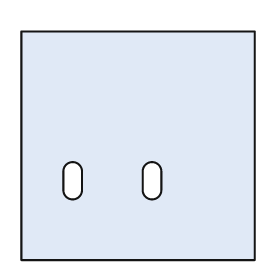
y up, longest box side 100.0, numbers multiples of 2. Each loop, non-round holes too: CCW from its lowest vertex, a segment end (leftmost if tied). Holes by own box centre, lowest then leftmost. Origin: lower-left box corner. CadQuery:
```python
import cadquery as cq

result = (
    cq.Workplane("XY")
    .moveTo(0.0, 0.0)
    .lineTo(100.0, 0.0)
    .lineTo(100.0, 98.0)
    .lineTo(0.0, 98.0)
    .close()
    .moveTo(18.0, 30.0)
    .threePointArc((22.0, 26.0), (26.0, 30.0))
    .lineTo(26.0, 38.0)
    .threePointArc((22.0, 42.0), (18.0, 38.0))
    .close()
    .moveTo(52.0, 30.0)
    .threePointArc((56.0, 26.0), (60.0, 30.0))
    .lineTo(60.0, 38.0)
    .threePointArc((56.0, 42.0), (52.0, 38.0))
    .close()
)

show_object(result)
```